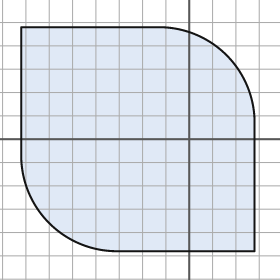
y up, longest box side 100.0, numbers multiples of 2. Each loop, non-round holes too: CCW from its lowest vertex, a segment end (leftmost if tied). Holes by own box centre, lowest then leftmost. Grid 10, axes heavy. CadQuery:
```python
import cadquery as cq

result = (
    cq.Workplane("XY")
    .moveTo(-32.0, -48.0)
    .lineTo(28.0, -48.0)
    .lineTo(28.0, 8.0)
    .threePointArc((16.0, 36.0), (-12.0, 48.0))
    .lineTo(-72.0, 48.0)
    .lineTo(-72.0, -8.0)
    .threePointArc((-60.0, -36.0), (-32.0, -48.0))
    .close()
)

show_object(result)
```